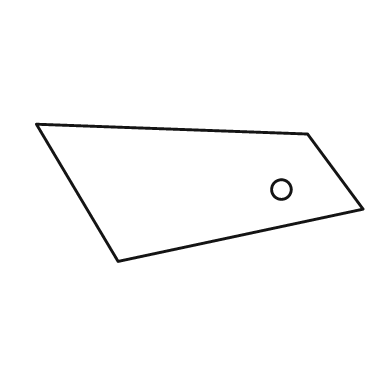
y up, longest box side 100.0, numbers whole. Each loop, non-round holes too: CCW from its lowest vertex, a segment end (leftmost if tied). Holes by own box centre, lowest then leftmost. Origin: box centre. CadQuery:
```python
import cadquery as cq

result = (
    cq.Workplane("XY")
    .moveTo(-25.0, -21.0)
    .lineTo(50.0, -5.0)
    .lineTo(33.0, 18.0)
    .lineTo(-50.0, 21.0)
    .close()
    .moveTo(25.0, 1.0)
    .circle(3.0)
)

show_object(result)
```